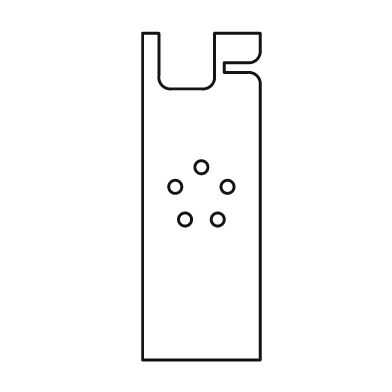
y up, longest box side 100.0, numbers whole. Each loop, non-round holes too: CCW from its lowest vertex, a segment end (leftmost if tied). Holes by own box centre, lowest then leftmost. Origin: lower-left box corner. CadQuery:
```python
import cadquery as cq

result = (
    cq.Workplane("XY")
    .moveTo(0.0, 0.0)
    .lineTo(36.0, 0.0)
    .lineTo(36.0, 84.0)
    .threePointArc((35.0, 87.0), (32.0, 88.0))
    .lineTo(25.0, 88.0)
    .lineTo(25.0, 91.0)
    .lineTo(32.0, 91.0)
    .threePointArc((35.0, 92.0), (36.0, 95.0))
    .lineTo(36.0, 100.0)
    .lineTo(22.0, 100.0)
    .lineTo(22.0, 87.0)
    .threePointArc((21.0, 84.0), (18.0, 83.0))
    .lineTo(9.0, 83.0)
    .threePointArc((6.0, 84.0), (5.0, 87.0))
    .lineTo(5.0, 100.0)
    .lineTo(0.0, 100.0)
    .close()
    .moveTo(13.0, 43.0)
    .circle(2.0)
    .moveTo(23.0, 43.0)
    .circle(2.0)
    .moveTo(10.0, 53.0)
    .circle(2.0)
    .moveTo(26.0, 53.0)
    .circle(2.0)
    .moveTo(18.0, 59.0)
    .circle(2.0)
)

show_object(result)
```